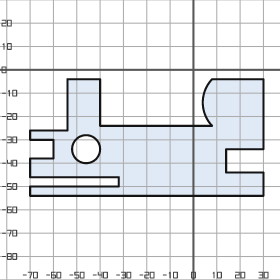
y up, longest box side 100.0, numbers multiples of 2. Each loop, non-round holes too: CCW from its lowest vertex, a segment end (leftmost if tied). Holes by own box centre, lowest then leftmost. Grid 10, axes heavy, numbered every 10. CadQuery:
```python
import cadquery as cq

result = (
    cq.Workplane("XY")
    .moveTo(-70.0, -54.0)
    .lineTo(30.0, -54.0)
    .lineTo(30.0, -44.0)
    .lineTo(14.0, -44.0)
    .lineTo(14.0, -34.0)
    .lineTo(30.0, -34.0)
    .lineTo(30.0, -4.0)
    .lineTo(8.0, -4.0)
    .threePointArc((4.0, -14.0), (8.0, -24.0))
    .lineTo(-40.0, -24.0)
    .lineTo(-40.0, -4.0)
    .lineTo(-54.0, -4.0)
    .lineTo(-54.0, -26.0)
    .lineTo(-70.0, -26.0)
    .lineTo(-70.0, -30.0)
    .lineTo(-60.0, -30.0)
    .lineTo(-60.0, -38.0)
    .lineTo(-70.0, -38.0)
    .lineTo(-70.0, -46.0)
    .lineTo(-32.0, -46.0)
    .lineTo(-32.0, -50.0)
    .lineTo(-70.0, -50.0)
    .close()
    .moveTo(-46.0, -34.0)
    .circle(6.0)
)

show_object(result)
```